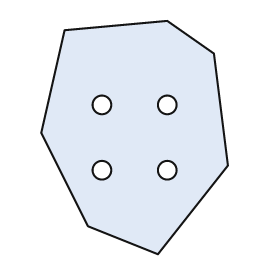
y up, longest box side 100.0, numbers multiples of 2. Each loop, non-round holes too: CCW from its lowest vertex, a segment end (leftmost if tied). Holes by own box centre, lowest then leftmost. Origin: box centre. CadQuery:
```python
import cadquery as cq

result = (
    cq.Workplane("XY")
    .moveTo(10.0, -50.0)
    .lineTo(40.0, -12.0)
    .lineTo(34.0, 36.0)
    .lineTo(14.0, 50.0)
    .lineTo(-30.0, 46.0)
    .lineTo(-40.0, 2.0)
    .lineTo(-20.0, -38.0)
    .close()
    .moveTo(-14.0, -14.0)
    .circle(4.0)
    .moveTo(14.0, -14.0)
    .circle(4.0)
    .moveTo(-14.0, 14.0)
    .circle(4.0)
    .moveTo(14.0, 14.0)
    .circle(4.0)
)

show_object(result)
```